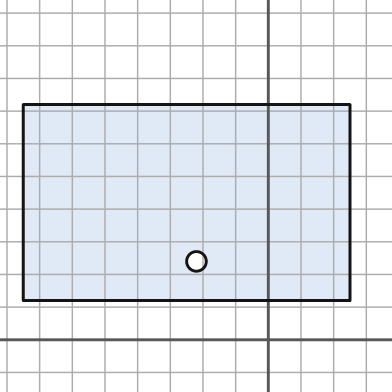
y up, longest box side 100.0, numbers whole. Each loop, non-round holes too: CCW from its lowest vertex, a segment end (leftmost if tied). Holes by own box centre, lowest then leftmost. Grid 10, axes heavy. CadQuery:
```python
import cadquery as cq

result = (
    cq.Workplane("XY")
    .moveTo(-75.0, 12.0)
    .lineTo(25.0, 12.0)
    .lineTo(25.0, 72.0)
    .lineTo(-75.0, 72.0)
    .close()
    .moveTo(-22.0, 24.0)
    .circle(3.0)
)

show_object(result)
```